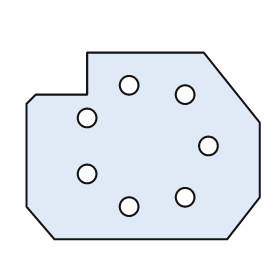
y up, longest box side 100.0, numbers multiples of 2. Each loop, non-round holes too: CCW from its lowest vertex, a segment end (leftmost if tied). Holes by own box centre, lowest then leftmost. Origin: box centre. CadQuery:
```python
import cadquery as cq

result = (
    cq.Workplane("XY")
    .moveTo(-38.0, -40.0)
    .lineTo(36.0, -40.0)
    .lineTo(50.0, -22.0)
    .lineTo(50.0, 10.0)
    .lineTo(26.0, 40.0)
    .lineTo(-24.0, 40.0)
    .lineTo(-24.0, 22.0)
    .lineTo(-46.0, 22.0)
    .lineTo(-50.0, 18.0)
    .lineTo(-50.0, -26.0)
    .close()
    .moveTo(-6.0, -26.0)
    .circle(4.0)
    .moveTo(18.0, -22.0)
    .circle(4.0)
    .moveTo(-24.0, -12.0)
    .circle(4.0)
    .moveTo(28.0, 0.0)
    .circle(4.0)
    .moveTo(-24.0, 12.0)
    .circle(4.0)
    .moveTo(18.0, 22.0)
    .circle(4.0)
    .moveTo(-6.0, 26.0)
    .circle(4.0)
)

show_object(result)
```